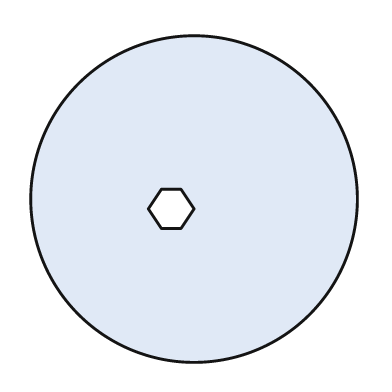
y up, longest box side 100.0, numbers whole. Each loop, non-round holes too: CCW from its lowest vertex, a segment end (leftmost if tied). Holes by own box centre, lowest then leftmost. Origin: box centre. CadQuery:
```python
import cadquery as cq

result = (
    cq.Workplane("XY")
    .moveTo(0.0, 0.0)
    .circle(50.0)
    .moveTo(-10.0, -9.0)
    .lineTo(-4.0, -9.0)
    .lineTo(0.0, -3.0)
    .lineTo(-4.0, 3.0)
    .lineTo(-10.0, 3.0)
    .lineTo(-14.0, -3.0)
    .close()
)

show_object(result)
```